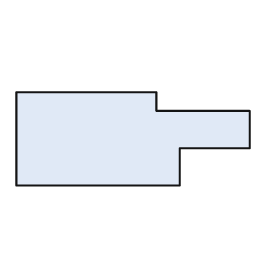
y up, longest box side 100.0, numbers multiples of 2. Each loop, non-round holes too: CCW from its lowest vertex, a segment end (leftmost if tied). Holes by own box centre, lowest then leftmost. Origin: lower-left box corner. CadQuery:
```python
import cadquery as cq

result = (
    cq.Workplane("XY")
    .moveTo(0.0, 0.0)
    .lineTo(70.0, 0.0)
    .lineTo(70.0, 16.0)
    .lineTo(100.0, 16.0)
    .lineTo(100.0, 32.0)
    .lineTo(60.0, 32.0)
    .lineTo(60.0, 40.0)
    .lineTo(0.0, 40.0)
    .close()
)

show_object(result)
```